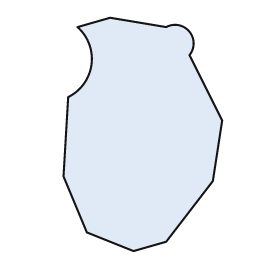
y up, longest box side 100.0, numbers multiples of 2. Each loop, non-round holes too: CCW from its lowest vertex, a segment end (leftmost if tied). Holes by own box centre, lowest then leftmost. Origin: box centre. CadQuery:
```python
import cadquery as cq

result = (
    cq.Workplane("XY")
    .moveTo(-4.0, -50.0)
    .lineTo(10.0, -46.0)
    .lineTo(30.0, -20.0)
    .lineTo(34.0, 6.0)
    .lineTo(20.0, 34.0)
    .threePointArc((20.0, 44.0), (10.0, 46.0))
    .lineTo(-14.0, 50.0)
    .lineTo(-28.0, 46.0)
    .threePointArc((-22.0, 30.0), (-32.0, 16.0))
    .lineTo(-34.0, -18.0)
    .lineTo(-24.0, -42.0)
    .close()
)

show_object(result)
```